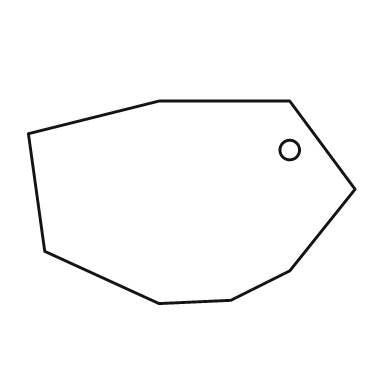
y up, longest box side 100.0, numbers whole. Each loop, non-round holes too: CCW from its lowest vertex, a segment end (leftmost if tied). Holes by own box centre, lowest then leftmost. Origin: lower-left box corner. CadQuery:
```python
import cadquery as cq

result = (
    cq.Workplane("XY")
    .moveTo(40.0, 0.0)
    .lineTo(62.0, 1.0)
    .lineTo(80.0, 10.0)
    .lineTo(100.0, 35.0)
    .lineTo(80.0, 62.0)
    .lineTo(40.0, 62.0)
    .lineTo(0.0, 52.0)
    .lineTo(5.0, 16.0)
    .close()
    .moveTo(80.0, 47.0)
    .circle(3.0)
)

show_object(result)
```